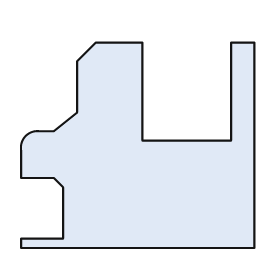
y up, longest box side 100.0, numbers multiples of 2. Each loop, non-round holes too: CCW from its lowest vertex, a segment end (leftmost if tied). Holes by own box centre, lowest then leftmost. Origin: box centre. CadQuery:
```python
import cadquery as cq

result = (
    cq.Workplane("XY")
    .moveTo(-50.0, -44.0)
    .lineTo(50.0, -44.0)
    .lineTo(50.0, 44.0)
    .lineTo(40.0, 44.0)
    .lineTo(40.0, 2.0)
    .lineTo(2.0, 2.0)
    .lineTo(2.0, 44.0)
    .lineTo(-18.0, 44.0)
    .lineTo(-26.0, 36.0)
    .lineTo(-26.0, 14.0)
    .lineTo(-36.0, 6.0)
    .lineTo(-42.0, 6.0)
    .threePointArc((-48.0, 4.0), (-50.0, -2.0))
    .lineTo(-50.0, -14.0)
    .lineTo(-36.0, -14.0)
    .lineTo(-32.0, -18.0)
    .lineTo(-32.0, -40.0)
    .lineTo(-50.0, -40.0)
    .close()
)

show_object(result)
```